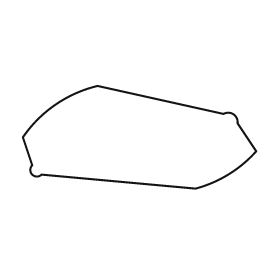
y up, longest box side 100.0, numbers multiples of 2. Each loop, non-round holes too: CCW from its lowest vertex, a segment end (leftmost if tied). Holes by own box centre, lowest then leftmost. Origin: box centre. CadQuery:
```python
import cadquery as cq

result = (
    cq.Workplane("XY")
    .moveTo(24.0, -22.0)
    .threePointArc((38.0, -16.0), (50.0, -6.0))
    .lineTo(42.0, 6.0)
    .threePointArc((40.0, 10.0), (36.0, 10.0))
    .lineTo(-18.0, 22.0)
    .threePointArc((-36.0, 14.0), (-50.0, 0.0))
    .lineTo(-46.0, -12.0)
    .threePointArc((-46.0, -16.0), (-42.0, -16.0))
    .close()
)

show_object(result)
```